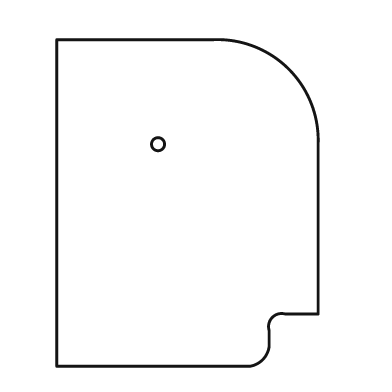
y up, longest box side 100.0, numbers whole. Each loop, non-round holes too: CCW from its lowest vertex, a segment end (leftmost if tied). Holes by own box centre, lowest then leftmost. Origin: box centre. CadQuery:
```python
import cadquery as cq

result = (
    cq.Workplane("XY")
    .moveTo(-40.0, -50.0)
    .lineTo(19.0, -50.0)
    .threePointArc((23.0, -48.0), (25.0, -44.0))
    .lineTo(25.0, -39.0)
    .threePointArc((26.0, -35.0), (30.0, -34.0))
    .lineTo(40.0, -34.0)
    .lineTo(40.0, 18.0)
    .threePointArc((31.0, 41.0), (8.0, 50.0))
    .lineTo(-40.0, 50.0)
    .close()
    .moveTo(-9.0, 18.0)
    .circle(2.0)
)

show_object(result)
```